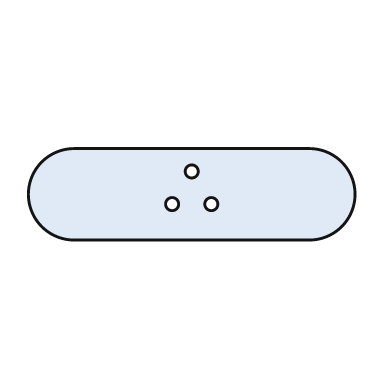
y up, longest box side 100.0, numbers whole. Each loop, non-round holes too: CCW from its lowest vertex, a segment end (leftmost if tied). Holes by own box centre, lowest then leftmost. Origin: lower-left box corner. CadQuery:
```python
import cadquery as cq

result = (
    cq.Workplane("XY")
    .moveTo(14.0, 0.0)
    .lineTo(86.0, 0.0)
    .threePointArc((100.0, 14.0), (86.0, 28.0))
    .lineTo(14.0, 28.0)
    .threePointArc((0.0, 14.0), (14.0, 0.0))
    .close()
    .moveTo(44.0, 11.0)
    .circle(2.0)
    .moveTo(56.0, 11.0)
    .circle(2.0)
    .moveTo(50.0, 21.0)
    .circle(2.0)
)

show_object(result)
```